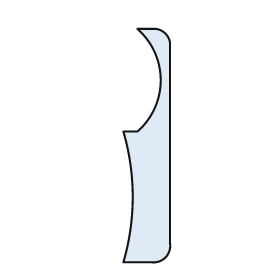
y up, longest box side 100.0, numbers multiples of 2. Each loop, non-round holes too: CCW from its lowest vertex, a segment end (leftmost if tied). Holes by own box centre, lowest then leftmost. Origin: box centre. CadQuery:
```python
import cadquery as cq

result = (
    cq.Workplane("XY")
    .moveTo(-10.0, -50.0)
    .lineTo(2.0, -50.0)
    .threePointArc((8.0, -48.0), (10.0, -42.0))
    .lineTo(10.0, 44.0)
    .threePointArc((8.0, 48.0), (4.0, 50.0))
    .lineTo(-4.0, 50.0)
    .threePointArc((6.0, 28.0), (-4.0, 6.0))
    .lineTo(-10.0, 6.0)
    .threePointArc((-6.0, -22.0), (-10.0, -50.0))
    .close()
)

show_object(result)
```